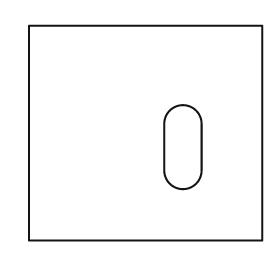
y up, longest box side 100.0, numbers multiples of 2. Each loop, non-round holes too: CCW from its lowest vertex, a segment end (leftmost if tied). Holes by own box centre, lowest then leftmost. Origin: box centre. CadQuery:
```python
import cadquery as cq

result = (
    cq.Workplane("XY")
    .moveTo(-50.0, -46.0)
    .lineTo(50.0, -46.0)
    .lineTo(50.0, 46.0)
    .lineTo(-50.0, 46.0)
    .close()
    .moveTo(8.0, -16.0)
    .threePointArc((16.0, -24.0), (24.0, -16.0))
    .lineTo(24.0, 4.0)
    .threePointArc((16.0, 12.0), (8.0, 4.0))
    .close()
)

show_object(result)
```